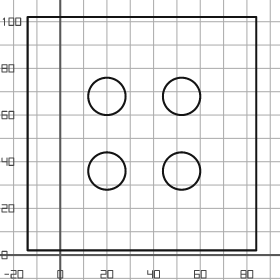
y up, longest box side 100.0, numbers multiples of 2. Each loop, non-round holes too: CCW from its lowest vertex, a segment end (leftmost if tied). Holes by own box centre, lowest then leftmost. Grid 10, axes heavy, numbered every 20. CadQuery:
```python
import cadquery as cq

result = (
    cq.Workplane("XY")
    .moveTo(-14.0, 2.0)
    .lineTo(84.0, 2.0)
    .lineTo(84.0, 102.0)
    .lineTo(-14.0, 102.0)
    .close()
    .moveTo(20.0, 36.0)
    .circle(8.0)
    .moveTo(52.0, 36.0)
    .circle(8.0)
    .moveTo(20.0, 68.0)
    .circle(8.0)
    .moveTo(52.0, 68.0)
    .circle(8.0)
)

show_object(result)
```